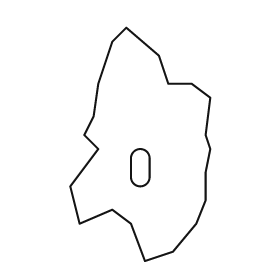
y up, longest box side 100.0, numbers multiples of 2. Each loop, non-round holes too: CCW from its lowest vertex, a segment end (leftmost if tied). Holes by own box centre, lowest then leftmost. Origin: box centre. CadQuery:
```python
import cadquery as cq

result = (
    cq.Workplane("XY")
    .moveTo(2.0, -50.0)
    .lineTo(14.0, -46.0)
    .lineTo(24.0, -34.0)
    .lineTo(28.0, -24.0)
    .lineTo(28.0, -12.0)
    .lineTo(30.0, -2.0)
    .lineTo(28.0, 4.0)
    .lineTo(30.0, 20.0)
    .lineTo(22.0, 26.0)
    .lineTo(12.0, 26.0)
    .lineTo(8.0, 38.0)
    .lineTo(-6.0, 50.0)
    .lineTo(-12.0, 44.0)
    .lineTo(-18.0, 26.0)
    .lineTo(-20.0, 12.0)
    .lineTo(-24.0, 4.0)
    .lineTo(-18.0, -2.0)
    .lineTo(-30.0, -18.0)
    .lineTo(-26.0, -34.0)
    .lineTo(-12.0, -28.0)
    .lineTo(-4.0, -34.0)
    .close()
    .moveTo(-4.0, -14.0)
    .threePointArc((0.0, -18.0), (4.0, -14.0))
    .lineTo(4.0, -6.0)
    .threePointArc((0.0, -2.0), (-4.0, -6.0))
    .close()
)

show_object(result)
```